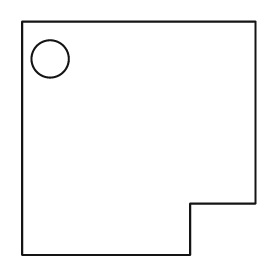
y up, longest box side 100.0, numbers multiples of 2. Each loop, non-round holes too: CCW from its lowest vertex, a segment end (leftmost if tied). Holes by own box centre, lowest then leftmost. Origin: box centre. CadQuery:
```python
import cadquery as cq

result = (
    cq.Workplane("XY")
    .moveTo(-50.0, -50.0)
    .lineTo(22.0, -50.0)
    .lineTo(22.0, -28.0)
    .lineTo(50.0, -28.0)
    .lineTo(50.0, 50.0)
    .lineTo(-50.0, 50.0)
    .close()
    .moveTo(-38.0, 34.0)
    .circle(8.0)
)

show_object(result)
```